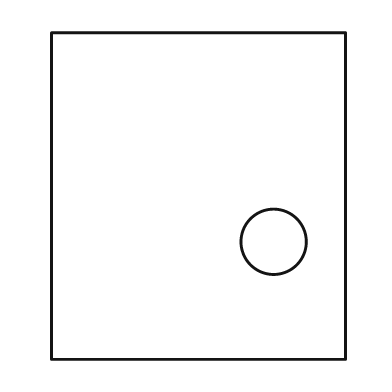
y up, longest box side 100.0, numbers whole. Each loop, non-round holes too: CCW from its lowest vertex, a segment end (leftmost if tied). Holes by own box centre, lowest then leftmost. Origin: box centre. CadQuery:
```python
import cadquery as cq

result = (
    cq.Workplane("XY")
    .moveTo(-45.0, -50.0)
    .lineTo(45.0, -50.0)
    .lineTo(45.0, 50.0)
    .lineTo(-45.0, 50.0)
    .close()
    .moveTo(23.0, -14.0)
    .circle(10.0)
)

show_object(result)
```